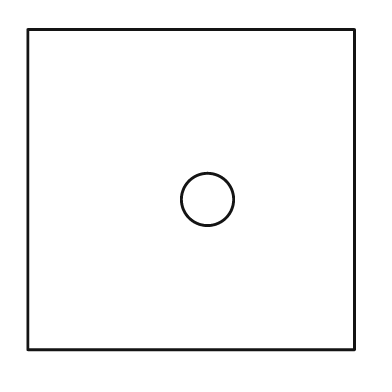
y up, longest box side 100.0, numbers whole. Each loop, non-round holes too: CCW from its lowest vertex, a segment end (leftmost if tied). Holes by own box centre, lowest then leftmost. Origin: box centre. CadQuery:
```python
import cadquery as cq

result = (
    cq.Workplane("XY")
    .moveTo(-50.0, -49.0)
    .lineTo(50.0, -49.0)
    .lineTo(50.0, 49.0)
    .lineTo(-50.0, 49.0)
    .close()
    .moveTo(5.0, -3.0)
    .circle(8.0)
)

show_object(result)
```